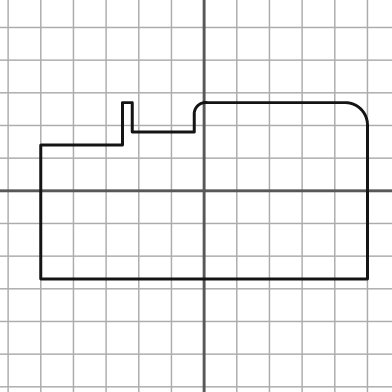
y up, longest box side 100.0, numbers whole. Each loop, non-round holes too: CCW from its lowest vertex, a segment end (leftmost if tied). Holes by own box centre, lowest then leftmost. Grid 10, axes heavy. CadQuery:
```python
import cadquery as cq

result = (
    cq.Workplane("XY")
    .moveTo(-50.0, -27.0)
    .lineTo(50.0, -27.0)
    .lineTo(50.0, 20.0)
    .threePointArc((48.0, 25.0), (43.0, 27.0))
    .lineTo(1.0, 27.0)
    .threePointArc((-2.0, 26.0), (-3.0, 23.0))
    .lineTo(-3.0, 18.0)
    .lineTo(-22.0, 18.0)
    .lineTo(-22.0, 27.0)
    .lineTo(-25.0, 27.0)
    .lineTo(-25.0, 14.0)
    .lineTo(-50.0, 14.0)
    .close()
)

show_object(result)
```